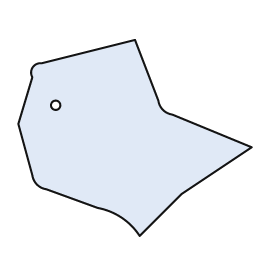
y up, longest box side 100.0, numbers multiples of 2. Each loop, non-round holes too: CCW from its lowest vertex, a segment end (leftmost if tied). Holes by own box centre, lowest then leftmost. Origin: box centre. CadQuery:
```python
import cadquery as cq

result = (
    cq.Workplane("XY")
    .moveTo(2.0, -42.0)
    .lineTo(20.0, -24.0)
    .lineTo(50.0, -4.0)
    .lineTo(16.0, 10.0)
    .threePointArc((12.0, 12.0), (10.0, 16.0))
    .lineTo(0.0, 42.0)
    .lineTo(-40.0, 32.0)
    .threePointArc((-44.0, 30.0), (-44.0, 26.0))
    .lineTo(-50.0, 6.0)
    .lineTo(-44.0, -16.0)
    .threePointArc((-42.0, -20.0), (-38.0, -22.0))
    .lineTo(-16.0, -30.0)
    .threePointArc((-6.0, -34.0), (2.0, -42.0))
    .close()
    .moveTo(-34.0, 14.0)
    .circle(2.0)
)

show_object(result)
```